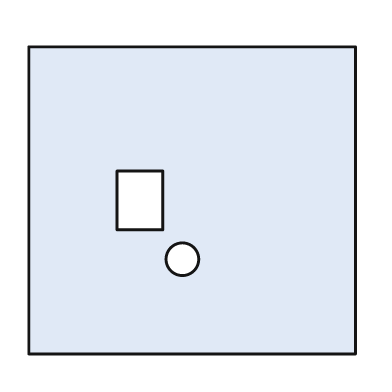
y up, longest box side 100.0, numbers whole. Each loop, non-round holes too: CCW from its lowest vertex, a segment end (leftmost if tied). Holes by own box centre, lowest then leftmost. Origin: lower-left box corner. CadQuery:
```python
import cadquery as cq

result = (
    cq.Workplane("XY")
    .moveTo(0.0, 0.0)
    .lineTo(100.0, 0.0)
    .lineTo(100.0, 94.0)
    .lineTo(0.0, 94.0)
    .close()
    .moveTo(47.0, 29.0)
    .circle(5.0)
    .moveTo(27.0, 38.0)
    .lineTo(41.0, 38.0)
    .lineTo(41.0, 56.0)
    .lineTo(27.0, 56.0)
    .close()
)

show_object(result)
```